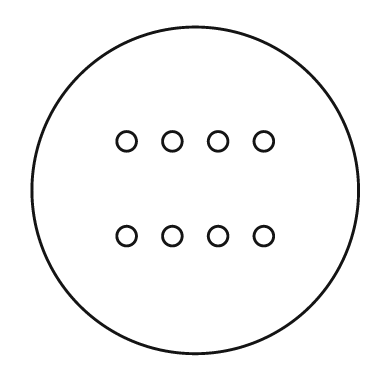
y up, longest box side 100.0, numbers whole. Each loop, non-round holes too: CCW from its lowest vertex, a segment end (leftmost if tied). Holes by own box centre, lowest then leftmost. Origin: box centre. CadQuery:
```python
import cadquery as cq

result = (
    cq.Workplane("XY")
    .moveTo(0.0, 0.0)
    .circle(50.0)
    .moveTo(-21.0, -14.0)
    .circle(3.0)
    .moveTo(-7.0, -14.0)
    .circle(3.0)
    .moveTo(7.0, -14.0)
    .circle(3.0)
    .moveTo(21.0, -14.0)
    .circle(3.0)
    .moveTo(-21.0, 15.0)
    .circle(3.0)
    .moveTo(-7.0, 15.0)
    .circle(3.0)
    .moveTo(7.0, 15.0)
    .circle(3.0)
    .moveTo(21.0, 15.0)
    .circle(3.0)
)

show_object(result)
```